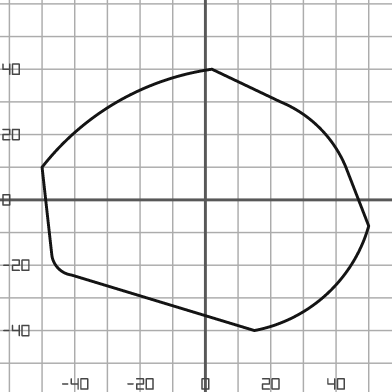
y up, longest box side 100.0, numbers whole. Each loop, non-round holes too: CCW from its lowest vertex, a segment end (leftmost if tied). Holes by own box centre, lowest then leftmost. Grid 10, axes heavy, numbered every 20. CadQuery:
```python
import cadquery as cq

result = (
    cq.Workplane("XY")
    .moveTo(15.0, -40.0)
    .threePointArc((37.0, -29.0), (50.0, -8.0))
    .lineTo(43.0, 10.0)
    .threePointArc((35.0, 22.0), (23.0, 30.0))
    .lineTo(2.0, 40.0)
    .threePointArc((-27.0, 30.0), (-50.0, 10.0))
    .lineTo(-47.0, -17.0)
    .threePointArc((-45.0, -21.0), (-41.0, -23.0))
    .close()
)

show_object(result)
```